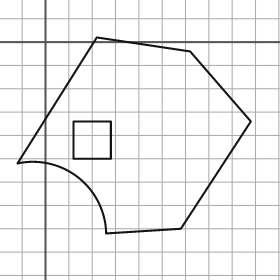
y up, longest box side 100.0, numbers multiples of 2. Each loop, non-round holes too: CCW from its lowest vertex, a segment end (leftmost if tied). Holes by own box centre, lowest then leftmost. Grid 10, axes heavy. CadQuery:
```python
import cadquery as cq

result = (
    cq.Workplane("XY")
    .moveTo(26.0, -82.0)
    .lineTo(58.0, -80.0)
    .lineTo(88.0, -34.0)
    .lineTo(62.0, -4.0)
    .lineTo(22.0, 2.0)
    .lineTo(-12.0, -52.0)
    .threePointArc((14.0, -58.0), (26.0, -82.0))
    .close()
    .moveTo(12.0, -50.0)
    .lineTo(28.0, -50.0)
    .lineTo(28.0, -34.0)
    .lineTo(12.0, -34.0)
    .close()
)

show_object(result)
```